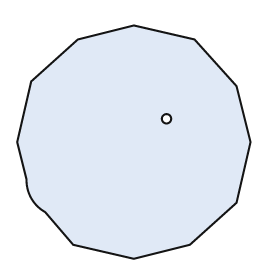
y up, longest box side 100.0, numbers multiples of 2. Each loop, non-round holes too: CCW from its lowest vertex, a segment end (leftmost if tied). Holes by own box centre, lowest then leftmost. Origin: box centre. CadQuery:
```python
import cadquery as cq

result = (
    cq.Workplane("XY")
    .moveTo(0.0, -50.0)
    .lineTo(24.0, -44.0)
    .lineTo(44.0, -26.0)
    .lineTo(50.0, 0.0)
    .lineTo(44.0, 24.0)
    .lineTo(26.0, 44.0)
    .lineTo(0.0, 50.0)
    .lineTo(-24.0, 44.0)
    .lineTo(-44.0, 26.0)
    .lineTo(-50.0, 0.0)
    .lineTo(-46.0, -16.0)
    .threePointArc((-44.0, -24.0), (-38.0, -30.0))
    .lineTo(-26.0, -44.0)
    .close()
    .moveTo(14.0, 10.0)
    .circle(2.0)
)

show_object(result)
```